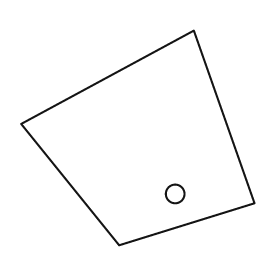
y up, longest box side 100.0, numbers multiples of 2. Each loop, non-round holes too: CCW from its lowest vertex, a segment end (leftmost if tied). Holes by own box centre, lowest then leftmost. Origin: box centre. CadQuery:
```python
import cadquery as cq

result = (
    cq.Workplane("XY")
    .moveTo(-8.0, -46.0)
    .lineTo(50.0, -28.0)
    .lineTo(24.0, 46.0)
    .lineTo(-50.0, 6.0)
    .close()
    .moveTo(16.0, -24.0)
    .circle(4.0)
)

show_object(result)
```